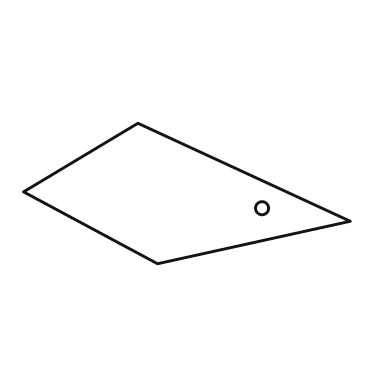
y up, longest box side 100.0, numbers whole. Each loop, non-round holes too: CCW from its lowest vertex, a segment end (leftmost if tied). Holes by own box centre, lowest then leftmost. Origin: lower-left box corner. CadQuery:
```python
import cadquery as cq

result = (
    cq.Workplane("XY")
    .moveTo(41.0, 0.0)
    .lineTo(100.0, 13.0)
    .lineTo(35.0, 43.0)
    .lineTo(0.0, 22.0)
    .close()
    .moveTo(73.0, 17.0)
    .circle(2.0)
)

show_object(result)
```